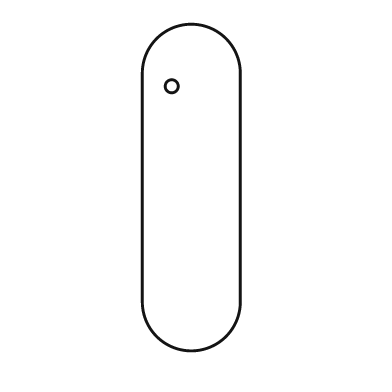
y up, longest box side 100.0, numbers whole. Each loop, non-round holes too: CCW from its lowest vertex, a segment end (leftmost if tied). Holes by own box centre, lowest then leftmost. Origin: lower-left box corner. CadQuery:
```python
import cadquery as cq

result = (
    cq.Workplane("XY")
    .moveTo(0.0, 15.0)
    .threePointArc((15.0, 0.0), (30.0, 15.0))
    .lineTo(30.0, 85.0)
    .threePointArc((15.0, 100.0), (0.0, 85.0))
    .close()
    .moveTo(9.0, 81.0)
    .circle(2.0)
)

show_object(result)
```